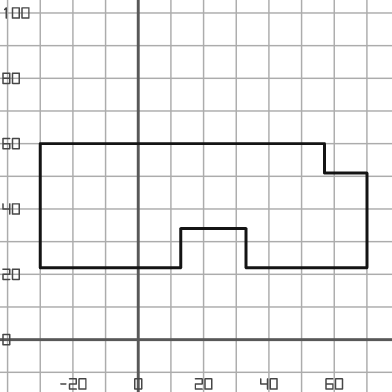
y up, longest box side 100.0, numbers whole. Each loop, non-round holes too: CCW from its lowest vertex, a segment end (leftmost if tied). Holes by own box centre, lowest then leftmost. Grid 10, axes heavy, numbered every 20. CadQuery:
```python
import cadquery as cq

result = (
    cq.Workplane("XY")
    .moveTo(-30.0, 22.0)
    .lineTo(13.0, 22.0)
    .lineTo(13.0, 34.0)
    .lineTo(33.0, 34.0)
    .lineTo(33.0, 22.0)
    .lineTo(70.0, 22.0)
    .lineTo(70.0, 51.0)
    .lineTo(57.0, 51.0)
    .lineTo(57.0, 60.0)
    .lineTo(-30.0, 60.0)
    .close()
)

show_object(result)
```